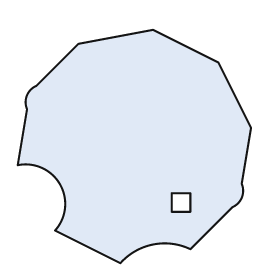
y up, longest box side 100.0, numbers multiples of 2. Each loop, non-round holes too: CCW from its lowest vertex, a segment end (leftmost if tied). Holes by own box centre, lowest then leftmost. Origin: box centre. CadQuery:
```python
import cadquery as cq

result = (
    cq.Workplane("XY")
    .moveTo(-6.0, -50.0)
    .threePointArc((8.0, -42.0), (24.0, -44.0))
    .lineTo(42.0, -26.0)
    .threePointArc((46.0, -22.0), (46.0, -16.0))
    .lineTo(50.0, 8.0)
    .lineTo(36.0, 36.0)
    .lineTo(8.0, 50.0)
    .lineTo(-24.0, 44.0)
    .lineTo(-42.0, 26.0)
    .threePointArc((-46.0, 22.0), (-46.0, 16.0))
    .lineTo(-50.0, -8.0)
    .threePointArc((-32.0, -16.0), (-34.0, -36.0))
    .close()
    .moveTo(16.0, -28.0)
    .lineTo(24.0, -28.0)
    .lineTo(24.0, -20.0)
    .lineTo(16.0, -20.0)
    .close()
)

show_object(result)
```